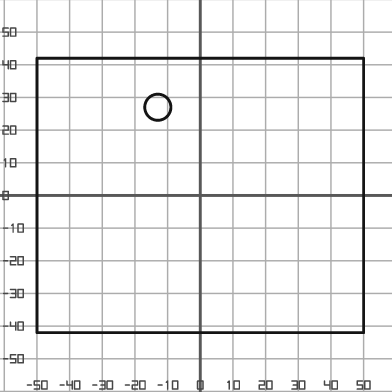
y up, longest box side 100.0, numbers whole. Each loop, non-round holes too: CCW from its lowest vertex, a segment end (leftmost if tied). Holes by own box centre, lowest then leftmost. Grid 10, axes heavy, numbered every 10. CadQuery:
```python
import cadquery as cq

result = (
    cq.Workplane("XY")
    .moveTo(-50.0, -42.0)
    .lineTo(50.0, -42.0)
    .lineTo(50.0, 42.0)
    .lineTo(-50.0, 42.0)
    .close()
    .moveTo(-13.0, 27.0)
    .circle(4.0)
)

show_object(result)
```